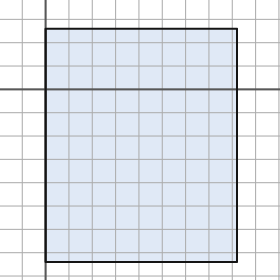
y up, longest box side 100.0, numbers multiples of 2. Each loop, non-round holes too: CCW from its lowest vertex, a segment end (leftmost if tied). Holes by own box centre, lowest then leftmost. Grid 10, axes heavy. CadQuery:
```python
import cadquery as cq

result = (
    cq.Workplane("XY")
    .moveTo(0.0, -74.0)
    .lineTo(82.0, -74.0)
    .lineTo(82.0, 26.0)
    .lineTo(0.0, 26.0)
    .close()
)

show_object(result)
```